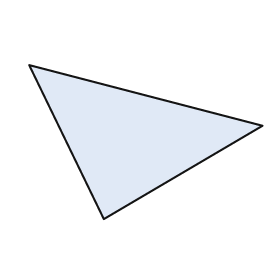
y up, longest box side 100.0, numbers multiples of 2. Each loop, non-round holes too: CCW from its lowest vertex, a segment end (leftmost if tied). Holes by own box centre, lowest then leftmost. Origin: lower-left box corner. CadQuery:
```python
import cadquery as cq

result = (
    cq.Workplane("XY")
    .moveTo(32.0, 0.0)
    .lineTo(100.0, 40.0)
    .lineTo(0.0, 66.0)
    .close()
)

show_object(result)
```